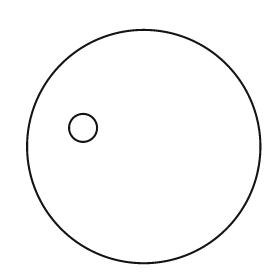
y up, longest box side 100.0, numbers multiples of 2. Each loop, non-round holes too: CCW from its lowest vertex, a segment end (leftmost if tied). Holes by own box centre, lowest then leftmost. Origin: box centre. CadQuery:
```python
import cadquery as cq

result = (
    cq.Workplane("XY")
    .moveTo(0.0, 0.0)
    .circle(50.0)
    .moveTo(-26.0, 8.0)
    .circle(6.0)
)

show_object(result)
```